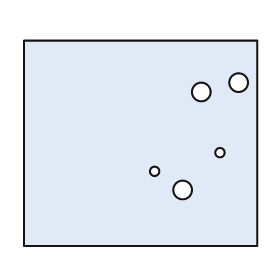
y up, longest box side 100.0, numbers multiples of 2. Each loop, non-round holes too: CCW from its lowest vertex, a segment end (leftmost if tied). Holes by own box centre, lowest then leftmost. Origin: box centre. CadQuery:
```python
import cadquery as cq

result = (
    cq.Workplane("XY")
    .moveTo(-50.0, -44.0)
    .lineTo(50.0, -44.0)
    .lineTo(50.0, 44.0)
    .lineTo(-50.0, 44.0)
    .close()
    .moveTo(18.0, -20.0)
    .circle(4.0)
    .moveTo(6.0, -12.0)
    .circle(2.0)
    .moveTo(34.0, -4.0)
    .circle(2.0)
    .moveTo(26.0, 22.0)
    .circle(4.0)
    .moveTo(42.0, 26.0)
    .circle(4.0)
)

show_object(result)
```